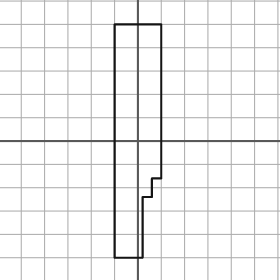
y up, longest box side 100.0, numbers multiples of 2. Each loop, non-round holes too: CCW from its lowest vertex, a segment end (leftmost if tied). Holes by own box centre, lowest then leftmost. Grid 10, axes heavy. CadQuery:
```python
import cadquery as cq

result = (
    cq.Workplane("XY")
    .moveTo(-10.0, -50.0)
    .lineTo(2.0, -50.0)
    .lineTo(2.0, -24.0)
    .lineTo(6.0, -24.0)
    .lineTo(6.0, -16.0)
    .lineTo(10.0, -16.0)
    .lineTo(10.0, 50.0)
    .lineTo(-10.0, 50.0)
    .close()
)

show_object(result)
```